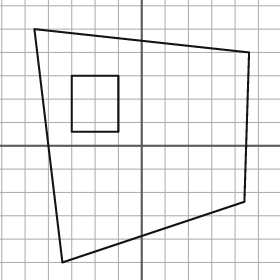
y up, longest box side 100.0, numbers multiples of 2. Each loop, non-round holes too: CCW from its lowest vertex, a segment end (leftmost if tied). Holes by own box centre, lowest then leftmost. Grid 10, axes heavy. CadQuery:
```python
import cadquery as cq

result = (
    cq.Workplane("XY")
    .moveTo(-34.0, -50.0)
    .lineTo(44.0, -24.0)
    .lineTo(46.0, 40.0)
    .lineTo(-46.0, 50.0)
    .close()
    .moveTo(-30.0, 6.0)
    .lineTo(-10.0, 6.0)
    .lineTo(-10.0, 30.0)
    .lineTo(-30.0, 30.0)
    .close()
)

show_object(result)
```